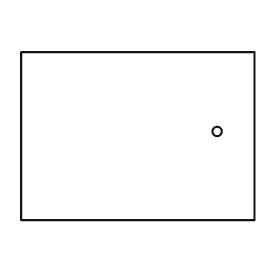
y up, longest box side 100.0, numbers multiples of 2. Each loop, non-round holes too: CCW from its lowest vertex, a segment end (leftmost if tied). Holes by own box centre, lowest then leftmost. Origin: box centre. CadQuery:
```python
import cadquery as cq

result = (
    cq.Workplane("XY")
    .moveTo(-50.0, -36.0)
    .lineTo(50.0, -36.0)
    .lineTo(50.0, 36.0)
    .lineTo(-50.0, 36.0)
    .close()
    .moveTo(34.0, 2.0)
    .circle(2.0)
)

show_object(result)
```